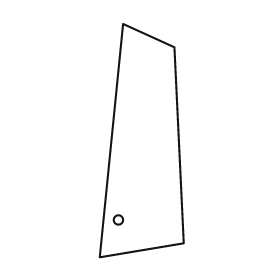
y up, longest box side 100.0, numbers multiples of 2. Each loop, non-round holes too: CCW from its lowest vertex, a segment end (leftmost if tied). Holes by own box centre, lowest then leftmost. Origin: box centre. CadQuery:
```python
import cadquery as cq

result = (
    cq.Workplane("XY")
    .moveTo(-18.0, -50.0)
    .lineTo(18.0, -44.0)
    .lineTo(14.0, 40.0)
    .lineTo(-8.0, 50.0)
    .close()
    .moveTo(-10.0, -34.0)
    .circle(2.0)
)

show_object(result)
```